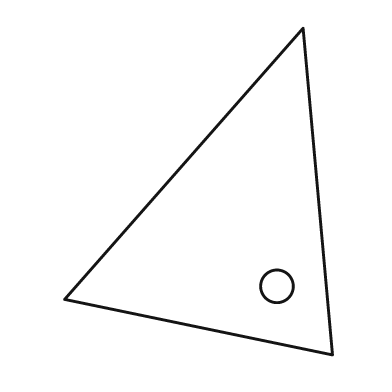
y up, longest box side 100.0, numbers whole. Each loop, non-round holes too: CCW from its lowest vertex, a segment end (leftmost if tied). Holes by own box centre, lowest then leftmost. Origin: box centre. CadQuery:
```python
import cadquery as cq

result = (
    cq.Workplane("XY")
    .moveTo(41.0, -50.0)
    .lineTo(32.0, 50.0)
    .lineTo(-41.0, -33.0)
    .close()
    .moveTo(24.0, -29.0)
    .circle(5.0)
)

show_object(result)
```